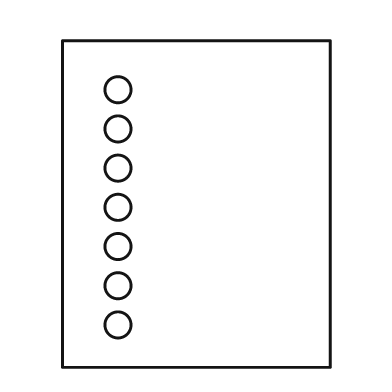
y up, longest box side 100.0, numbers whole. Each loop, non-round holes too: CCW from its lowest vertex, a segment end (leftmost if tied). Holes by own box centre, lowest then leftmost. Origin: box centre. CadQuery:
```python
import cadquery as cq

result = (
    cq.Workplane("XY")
    .moveTo(-41.0, -50.0)
    .lineTo(41.0, -50.0)
    .lineTo(41.0, 50.0)
    .lineTo(-41.0, 50.0)
    .close()
    .moveTo(-24.0, -37.0)
    .circle(4.0)
    .moveTo(-24.0, -25.0)
    .circle(4.0)
    .moveTo(-24.0, -13.0)
    .circle(4.0)
    .moveTo(-24.0, -1.0)
    .circle(4.0)
    .moveTo(-24.0, 11.0)
    .circle(4.0)
    .moveTo(-24.0, 23.0)
    .circle(4.0)
    .moveTo(-24.0, 35.0)
    .circle(4.0)
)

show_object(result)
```